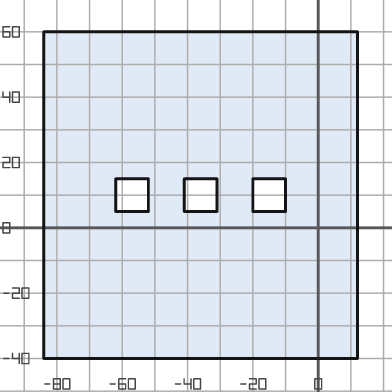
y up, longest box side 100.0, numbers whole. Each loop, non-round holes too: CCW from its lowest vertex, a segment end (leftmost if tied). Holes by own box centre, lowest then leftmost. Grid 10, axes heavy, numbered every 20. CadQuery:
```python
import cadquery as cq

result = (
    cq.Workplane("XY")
    .moveTo(-84.0, -40.0)
    .lineTo(12.0, -40.0)
    .lineTo(12.0, 60.0)
    .lineTo(-84.0, 60.0)
    .close()
    .moveTo(-62.0, 5.0)
    .lineTo(-52.0, 5.0)
    .lineTo(-52.0, 15.0)
    .lineTo(-62.0, 15.0)
    .close()
    .moveTo(-41.0, 5.0)
    .lineTo(-31.0, 5.0)
    .lineTo(-31.0, 15.0)
    .lineTo(-41.0, 15.0)
    .close()
    .moveTo(-20.0, 5.0)
    .lineTo(-10.0, 5.0)
    .lineTo(-10.0, 15.0)
    .lineTo(-20.0, 15.0)
    .close()
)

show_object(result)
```